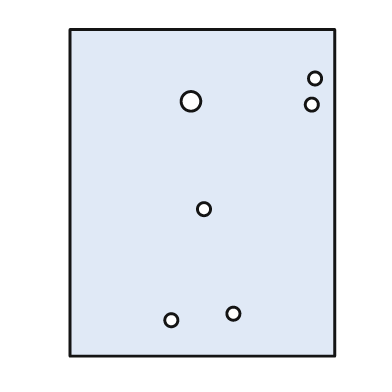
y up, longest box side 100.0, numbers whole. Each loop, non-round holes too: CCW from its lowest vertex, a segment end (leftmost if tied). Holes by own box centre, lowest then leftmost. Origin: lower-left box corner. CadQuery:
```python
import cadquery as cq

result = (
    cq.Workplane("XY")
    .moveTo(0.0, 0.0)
    .lineTo(81.0, 0.0)
    .lineTo(81.0, 100.0)
    .lineTo(0.0, 100.0)
    .close()
    .moveTo(31.0, 11.0)
    .circle(2.0)
    .moveTo(50.0, 13.0)
    .circle(2.0)
    .moveTo(41.0, 45.0)
    .circle(2.0)
    .moveTo(74.0, 77.0)
    .circle(2.0)
    .moveTo(37.0, 78.0)
    .circle(3.0)
    .moveTo(75.0, 85.0)
    .circle(2.0)
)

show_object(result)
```